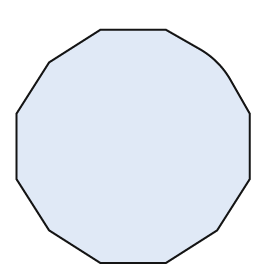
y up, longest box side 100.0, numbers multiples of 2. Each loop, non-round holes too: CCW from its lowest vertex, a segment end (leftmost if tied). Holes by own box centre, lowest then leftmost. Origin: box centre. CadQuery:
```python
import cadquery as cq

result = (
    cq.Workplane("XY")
    .moveTo(-14.0, -50.0)
    .lineTo(14.0, -50.0)
    .lineTo(36.0, -36.0)
    .lineTo(50.0, -14.0)
    .lineTo(50.0, 14.0)
    .lineTo(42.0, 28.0)
    .threePointArc((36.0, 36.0), (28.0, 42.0))
    .lineTo(14.0, 50.0)
    .lineTo(-14.0, 50.0)
    .lineTo(-36.0, 36.0)
    .lineTo(-50.0, 14.0)
    .lineTo(-50.0, -14.0)
    .lineTo(-36.0, -36.0)
    .close()
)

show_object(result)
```